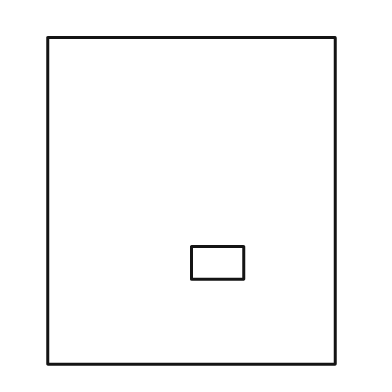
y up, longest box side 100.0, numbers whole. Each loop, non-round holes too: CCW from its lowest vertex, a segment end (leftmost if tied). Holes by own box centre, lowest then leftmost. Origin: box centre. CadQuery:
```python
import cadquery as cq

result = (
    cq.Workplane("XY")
    .moveTo(-44.0, -50.0)
    .lineTo(44.0, -50.0)
    .lineTo(44.0, 50.0)
    .lineTo(-44.0, 50.0)
    .close()
    .moveTo(0.0, -24.0)
    .lineTo(16.0, -24.0)
    .lineTo(16.0, -14.0)
    .lineTo(0.0, -14.0)
    .close()
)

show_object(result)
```